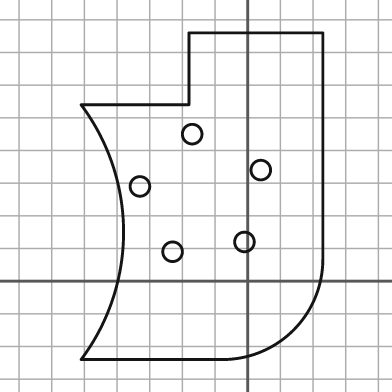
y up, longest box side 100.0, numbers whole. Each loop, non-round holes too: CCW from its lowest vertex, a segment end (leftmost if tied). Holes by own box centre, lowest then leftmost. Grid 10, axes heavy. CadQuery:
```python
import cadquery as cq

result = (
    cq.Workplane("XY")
    .moveTo(-51.0, -24.0)
    .lineTo(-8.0, -24.0)
    .threePointArc((14.0, -15.0), (23.0, 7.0))
    .lineTo(23.0, 76.0)
    .lineTo(-18.0, 76.0)
    .lineTo(-18.0, 54.0)
    .lineTo(-51.0, 54.0)
    .threePointArc((-38.0, 15.0), (-51.0, -24.0))
    .close()
    .moveTo(-23.0, 9.0)
    .circle(3.0)
    .moveTo(-1.0, 12.0)
    .circle(3.0)
    .moveTo(-33.0, 29.0)
    .circle(3.0)
    .moveTo(4.0, 34.0)
    .circle(3.0)
    .moveTo(-17.0, 45.0)
    .circle(3.0)
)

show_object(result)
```